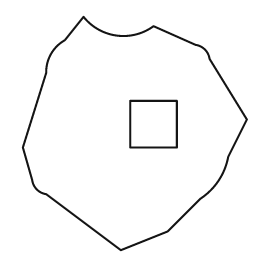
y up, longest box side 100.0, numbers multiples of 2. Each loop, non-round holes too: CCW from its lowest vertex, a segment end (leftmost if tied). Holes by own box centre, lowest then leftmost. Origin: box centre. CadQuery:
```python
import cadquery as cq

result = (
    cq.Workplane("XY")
    .moveTo(-6.0, -50.0)
    .lineTo(14.0, -42.0)
    .lineTo(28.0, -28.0)
    .threePointArc((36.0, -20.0), (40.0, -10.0))
    .lineTo(48.0, 6.0)
    .lineTo(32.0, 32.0)
    .threePointArc((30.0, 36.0), (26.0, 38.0))
    .lineTo(8.0, 46.0)
    .threePointArc((-8.0, 42.0), (-22.0, 50.0))
    .lineTo(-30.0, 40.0)
    .threePointArc((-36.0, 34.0), (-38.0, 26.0))
    .lineTo(-48.0, -6.0)
    .lineTo(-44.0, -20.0)
    .threePointArc((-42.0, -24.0), (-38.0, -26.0))
    .close()
    .moveTo(-2.0, -6.0)
    .lineTo(18.0, -6.0)
    .lineTo(18.0, 14.0)
    .lineTo(-2.0, 14.0)
    .close()
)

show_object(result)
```